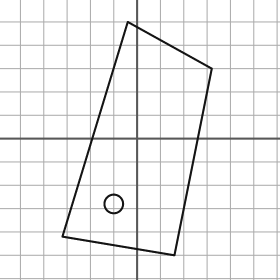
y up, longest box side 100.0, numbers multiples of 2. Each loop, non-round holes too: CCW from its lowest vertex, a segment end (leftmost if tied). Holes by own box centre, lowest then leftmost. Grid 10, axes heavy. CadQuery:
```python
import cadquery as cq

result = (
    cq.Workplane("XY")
    .moveTo(16.0, -50.0)
    .lineTo(32.0, 30.0)
    .lineTo(-4.0, 50.0)
    .lineTo(-32.0, -42.0)
    .close()
    .moveTo(-10.0, -28.0)
    .circle(4.0)
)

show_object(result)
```